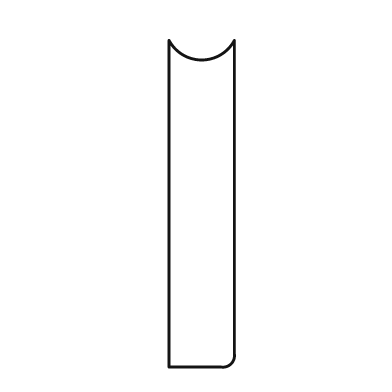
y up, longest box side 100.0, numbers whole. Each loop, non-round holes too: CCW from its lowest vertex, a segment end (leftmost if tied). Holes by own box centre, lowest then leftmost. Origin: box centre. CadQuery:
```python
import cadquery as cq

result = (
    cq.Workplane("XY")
    .moveTo(-10.0, -50.0)
    .lineTo(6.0, -50.0)
    .threePointArc((9.0, -49.0), (10.0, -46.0))
    .lineTo(10.0, 50.0)
    .threePointArc((0.0, 44.0), (-10.0, 50.0))
    .close()
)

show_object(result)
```